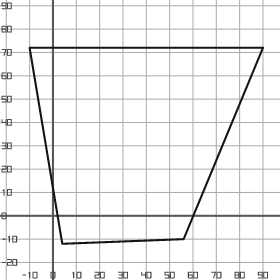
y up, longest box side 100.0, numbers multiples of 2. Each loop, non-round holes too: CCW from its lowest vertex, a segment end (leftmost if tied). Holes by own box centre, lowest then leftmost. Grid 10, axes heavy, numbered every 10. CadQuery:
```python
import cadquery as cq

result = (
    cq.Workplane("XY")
    .moveTo(4.0, -12.0)
    .lineTo(56.0, -10.0)
    .lineTo(90.0, 72.0)
    .lineTo(-10.0, 72.0)
    .close()
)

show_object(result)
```